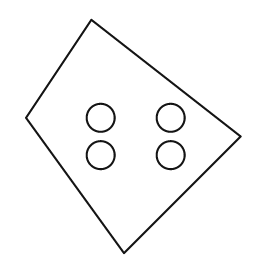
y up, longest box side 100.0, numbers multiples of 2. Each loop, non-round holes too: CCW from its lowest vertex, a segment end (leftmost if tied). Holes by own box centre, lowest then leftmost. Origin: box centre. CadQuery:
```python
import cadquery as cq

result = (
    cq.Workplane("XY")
    .moveTo(-4.0, -50.0)
    .lineTo(46.0, 0.0)
    .lineTo(-18.0, 50.0)
    .lineTo(-46.0, 8.0)
    .close()
    .moveTo(-14.0, -8.0)
    .circle(6.0)
    .moveTo(16.0, -8.0)
    .circle(6.0)
    .moveTo(-14.0, 8.0)
    .circle(6.0)
    .moveTo(16.0, 8.0)
    .circle(6.0)
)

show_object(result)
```